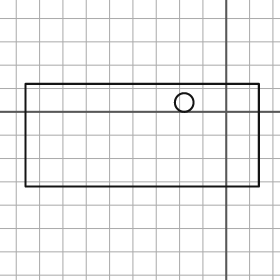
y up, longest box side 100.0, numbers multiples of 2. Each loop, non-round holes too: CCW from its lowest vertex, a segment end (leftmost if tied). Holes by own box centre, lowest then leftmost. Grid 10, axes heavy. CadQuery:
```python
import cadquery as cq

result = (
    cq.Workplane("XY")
    .moveTo(-86.0, -32.0)
    .lineTo(14.0, -32.0)
    .lineTo(14.0, 12.0)
    .lineTo(-86.0, 12.0)
    .close()
    .moveTo(-18.0, 4.0)
    .circle(4.0)
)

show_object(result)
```